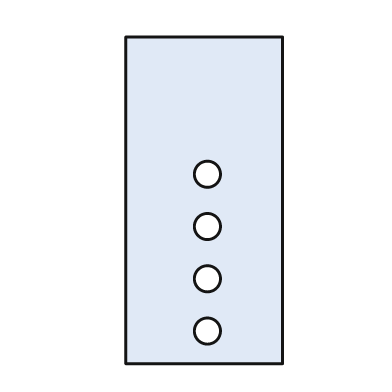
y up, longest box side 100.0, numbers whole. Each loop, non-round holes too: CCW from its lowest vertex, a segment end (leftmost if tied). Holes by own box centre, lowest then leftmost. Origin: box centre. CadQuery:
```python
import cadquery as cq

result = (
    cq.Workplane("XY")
    .moveTo(-24.0, -50.0)
    .lineTo(24.0, -50.0)
    .lineTo(24.0, 50.0)
    .lineTo(-24.0, 50.0)
    .close()
    .moveTo(1.0, -40.0)
    .circle(4.0)
    .moveTo(1.0, -24.0)
    .circle(4.0)
    .moveTo(1.0, -8.0)
    .circle(4.0)
    .moveTo(1.0, 8.0)
    .circle(4.0)
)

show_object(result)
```